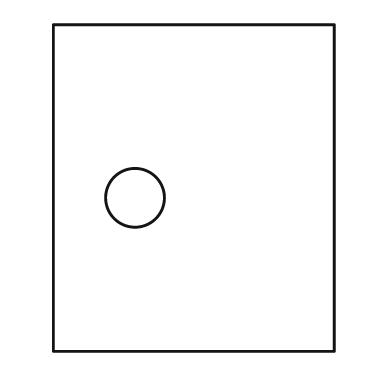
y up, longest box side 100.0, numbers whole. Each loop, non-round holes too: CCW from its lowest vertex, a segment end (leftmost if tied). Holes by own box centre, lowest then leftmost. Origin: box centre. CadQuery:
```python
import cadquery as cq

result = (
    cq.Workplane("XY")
    .moveTo(-43.0, -50.0)
    .lineTo(43.0, -50.0)
    .lineTo(43.0, 50.0)
    .lineTo(-43.0, 50.0)
    .close()
    .moveTo(-18.0, -3.0)
    .circle(9.0)
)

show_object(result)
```